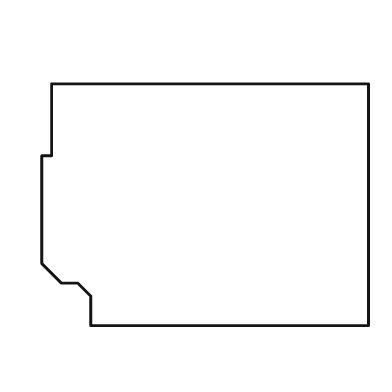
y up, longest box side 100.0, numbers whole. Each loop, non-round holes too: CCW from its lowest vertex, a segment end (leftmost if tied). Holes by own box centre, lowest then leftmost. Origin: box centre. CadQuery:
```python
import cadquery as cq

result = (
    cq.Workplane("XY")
    .moveTo(-35.0, -37.0)
    .lineTo(50.0, -37.0)
    .lineTo(50.0, 37.0)
    .lineTo(-47.0, 37.0)
    .lineTo(-47.0, 15.0)
    .lineTo(-50.0, 15.0)
    .lineTo(-50.0, -18.0)
    .lineTo(-44.0, -24.0)
    .lineTo(-39.0, -24.0)
    .lineTo(-35.0, -28.0)
    .close()
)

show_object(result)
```